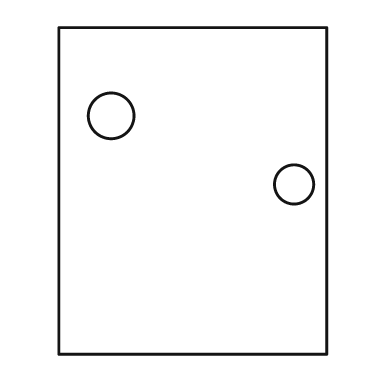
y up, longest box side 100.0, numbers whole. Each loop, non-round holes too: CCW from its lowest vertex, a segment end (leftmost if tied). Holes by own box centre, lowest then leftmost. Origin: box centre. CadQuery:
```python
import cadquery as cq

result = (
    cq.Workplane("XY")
    .moveTo(-41.0, -50.0)
    .lineTo(41.0, -50.0)
    .lineTo(41.0, 50.0)
    .lineTo(-41.0, 50.0)
    .close()
    .moveTo(31.0, 2.0)
    .circle(6.0)
    .moveTo(-25.0, 23.0)
    .circle(7.0)
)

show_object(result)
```